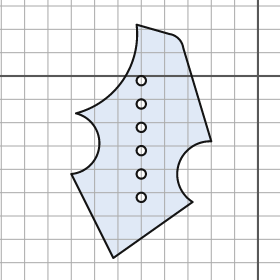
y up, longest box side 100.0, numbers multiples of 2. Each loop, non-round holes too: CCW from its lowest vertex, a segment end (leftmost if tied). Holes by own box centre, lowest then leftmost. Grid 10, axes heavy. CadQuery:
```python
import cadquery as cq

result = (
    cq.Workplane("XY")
    .moveTo(-62.0, -78.0)
    .lineTo(-28.0, -54.0)
    .threePointArc((-34.0, -38.0), (-20.0, -28.0))
    .lineTo(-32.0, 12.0)
    .threePointArc((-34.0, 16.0), (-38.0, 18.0))
    .lineTo(-52.0, 22.0)
    .threePointArc((-58.0, -2.0), (-78.0, -16.0))
    .threePointArc((-68.0, -30.0), (-80.0, -42.0))
    .close()
    .moveTo(-50.0, -52.0)
    .circle(2.0)
    .moveTo(-50.0, -42.0)
    .circle(2.0)
    .moveTo(-50.0, -32.0)
    .circle(2.0)
    .moveTo(-50.0, -22.0)
    .circle(2.0)
    .moveTo(-50.0, -12.0)
    .circle(2.0)
    .moveTo(-50.0, -2.0)
    .circle(2.0)
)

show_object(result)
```